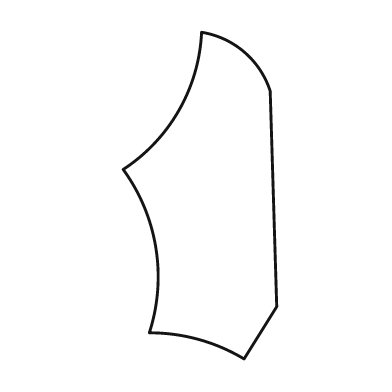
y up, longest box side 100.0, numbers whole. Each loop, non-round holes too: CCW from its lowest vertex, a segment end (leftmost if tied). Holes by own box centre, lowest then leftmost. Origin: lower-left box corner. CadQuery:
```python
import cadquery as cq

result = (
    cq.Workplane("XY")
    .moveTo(37.0, 0.0)
    .lineTo(47.0, 16.0)
    .lineTo(45.0, 82.0)
    .threePointArc((37.0, 94.0), (24.0, 100.0))
    .threePointArc((17.0, 76.0), (0.0, 58.0))
    .threePointArc((10.0, 34.0), (8.0, 8.0))
    .threePointArc((23.0, 6.0), (37.0, 0.0))
    .close()
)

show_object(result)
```